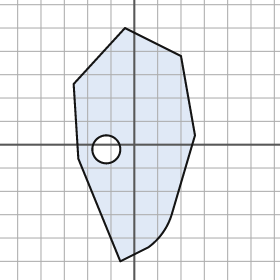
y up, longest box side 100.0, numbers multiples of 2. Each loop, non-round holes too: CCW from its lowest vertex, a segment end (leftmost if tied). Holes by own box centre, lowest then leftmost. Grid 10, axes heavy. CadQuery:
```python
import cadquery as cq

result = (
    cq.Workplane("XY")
    .moveTo(-6.0, -50.0)
    .lineTo(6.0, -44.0)
    .threePointArc((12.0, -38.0), (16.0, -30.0))
    .lineTo(26.0, 4.0)
    .lineTo(20.0, 38.0)
    .lineTo(-4.0, 50.0)
    .lineTo(-26.0, 26.0)
    .lineTo(-24.0, -6.0)
    .close()
    .moveTo(-12.0, -2.0)
    .circle(6.0)
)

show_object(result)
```